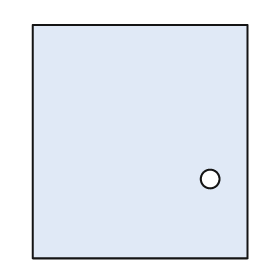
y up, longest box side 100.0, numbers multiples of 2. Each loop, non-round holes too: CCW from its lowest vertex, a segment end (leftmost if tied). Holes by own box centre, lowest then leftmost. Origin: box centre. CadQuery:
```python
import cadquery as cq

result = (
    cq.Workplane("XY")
    .moveTo(-46.0, -50.0)
    .lineTo(46.0, -50.0)
    .lineTo(46.0, 50.0)
    .lineTo(-46.0, 50.0)
    .close()
    .moveTo(30.0, -16.0)
    .circle(4.0)
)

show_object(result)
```